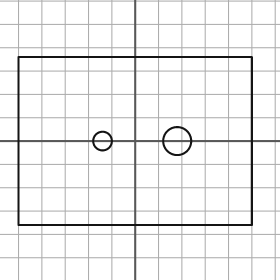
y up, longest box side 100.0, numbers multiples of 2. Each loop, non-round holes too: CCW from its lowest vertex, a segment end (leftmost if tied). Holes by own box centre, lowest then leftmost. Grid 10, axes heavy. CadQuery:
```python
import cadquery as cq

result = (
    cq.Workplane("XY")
    .moveTo(-50.0, -36.0)
    .lineTo(50.0, -36.0)
    .lineTo(50.0, 36.0)
    .lineTo(-50.0, 36.0)
    .close()
    .moveTo(-14.0, 0.0)
    .circle(4.0)
    .moveTo(18.0, 0.0)
    .circle(6.0)
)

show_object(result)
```